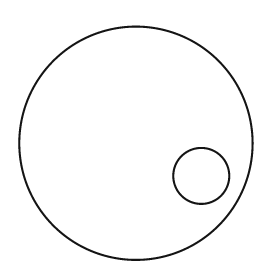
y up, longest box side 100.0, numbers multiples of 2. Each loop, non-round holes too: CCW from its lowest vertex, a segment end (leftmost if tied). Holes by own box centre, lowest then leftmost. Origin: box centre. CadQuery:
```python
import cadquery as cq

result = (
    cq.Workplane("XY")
    .moveTo(0.0, 0.0)
    .circle(50.0)
    .moveTo(28.0, -14.0)
    .circle(12.0)
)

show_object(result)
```